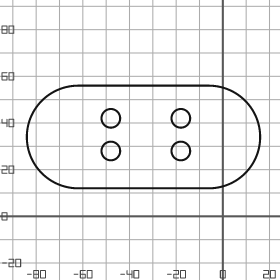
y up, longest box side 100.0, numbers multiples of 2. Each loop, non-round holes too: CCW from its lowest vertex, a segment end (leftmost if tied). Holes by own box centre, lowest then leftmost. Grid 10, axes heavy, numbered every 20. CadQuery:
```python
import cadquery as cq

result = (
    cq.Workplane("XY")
    .moveTo(-62.0, 12.0)
    .lineTo(-6.0, 12.0)
    .threePointArc((16.0, 34.0), (-6.0, 56.0))
    .lineTo(-62.0, 56.0)
    .threePointArc((-84.0, 34.0), (-62.0, 12.0))
    .close()
    .moveTo(-48.0, 28.0)
    .circle(4.0)
    .moveTo(-18.0, 28.0)
    .circle(4.0)
    .moveTo(-48.0, 42.0)
    .circle(4.0)
    .moveTo(-18.0, 42.0)
    .circle(4.0)
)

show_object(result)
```